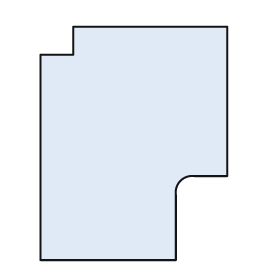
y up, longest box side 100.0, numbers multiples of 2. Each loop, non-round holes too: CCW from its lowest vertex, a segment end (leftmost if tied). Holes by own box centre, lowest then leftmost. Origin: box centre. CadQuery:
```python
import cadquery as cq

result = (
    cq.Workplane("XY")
    .moveTo(-40.0, -50.0)
    .lineTo(18.0, -50.0)
    .lineTo(18.0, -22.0)
    .threePointArc((20.0, -16.0), (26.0, -14.0))
    .lineTo(40.0, -14.0)
    .lineTo(40.0, 50.0)
    .lineTo(-26.0, 50.0)
    .lineTo(-26.0, 38.0)
    .lineTo(-40.0, 38.0)
    .close()
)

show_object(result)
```